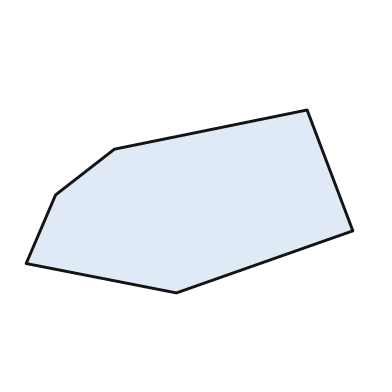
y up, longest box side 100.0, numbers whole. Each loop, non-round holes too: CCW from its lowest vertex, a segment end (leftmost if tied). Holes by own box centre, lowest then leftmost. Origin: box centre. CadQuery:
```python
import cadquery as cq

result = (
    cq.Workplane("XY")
    .moveTo(-4.0, -28.0)
    .lineTo(50.0, -9.0)
    .lineTo(36.0, 28.0)
    .lineTo(-23.0, 16.0)
    .lineTo(-41.0, 2.0)
    .lineTo(-50.0, -19.0)
    .close()
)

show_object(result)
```